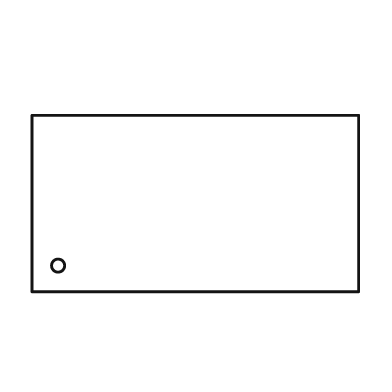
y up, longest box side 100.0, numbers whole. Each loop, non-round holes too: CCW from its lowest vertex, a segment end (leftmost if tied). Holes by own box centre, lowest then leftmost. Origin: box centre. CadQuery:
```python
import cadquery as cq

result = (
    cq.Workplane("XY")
    .moveTo(-50.0, -27.0)
    .lineTo(50.0, -27.0)
    .lineTo(50.0, 27.0)
    .lineTo(-50.0, 27.0)
    .close()
    .moveTo(-42.0, -19.0)
    .circle(2.0)
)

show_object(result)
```